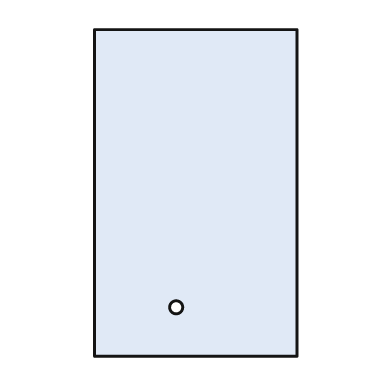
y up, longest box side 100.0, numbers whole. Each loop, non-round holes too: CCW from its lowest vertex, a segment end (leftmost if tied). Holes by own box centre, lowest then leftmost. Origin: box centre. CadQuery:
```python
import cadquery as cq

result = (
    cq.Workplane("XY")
    .moveTo(-31.0, -50.0)
    .lineTo(31.0, -50.0)
    .lineTo(31.0, 50.0)
    .lineTo(-31.0, 50.0)
    .close()
    .moveTo(-6.0, -35.0)
    .circle(2.0)
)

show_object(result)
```